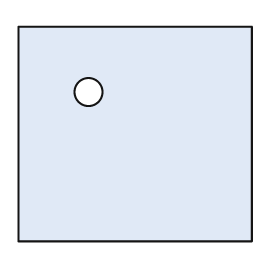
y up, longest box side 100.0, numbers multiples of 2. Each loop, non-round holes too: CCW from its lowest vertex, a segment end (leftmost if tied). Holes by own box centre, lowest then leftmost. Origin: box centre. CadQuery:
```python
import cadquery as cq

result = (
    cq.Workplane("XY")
    .moveTo(-50.0, -46.0)
    .lineTo(50.0, -46.0)
    .lineTo(50.0, 46.0)
    .lineTo(-50.0, 46.0)
    .close()
    .moveTo(-20.0, 18.0)
    .circle(6.0)
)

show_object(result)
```